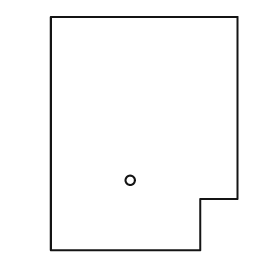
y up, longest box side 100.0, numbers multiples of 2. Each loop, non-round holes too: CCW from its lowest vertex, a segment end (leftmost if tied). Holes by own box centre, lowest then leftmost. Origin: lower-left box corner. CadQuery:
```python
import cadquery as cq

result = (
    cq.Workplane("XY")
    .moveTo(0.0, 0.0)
    .lineTo(64.0, 0.0)
    .lineTo(64.0, 22.0)
    .lineTo(80.0, 22.0)
    .lineTo(80.0, 100.0)
    .lineTo(0.0, 100.0)
    .close()
    .moveTo(34.0, 30.0)
    .circle(2.0)
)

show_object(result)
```